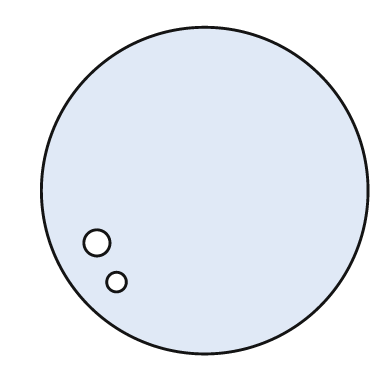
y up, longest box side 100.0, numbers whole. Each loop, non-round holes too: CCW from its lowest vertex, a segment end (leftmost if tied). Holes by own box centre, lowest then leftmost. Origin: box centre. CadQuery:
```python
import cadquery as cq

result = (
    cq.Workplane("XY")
    .moveTo(0.0, 0.0)
    .circle(50.0)
    .moveTo(-27.0, -28.0)
    .circle(3.0)
    .moveTo(-33.0, -16.0)
    .circle(4.0)
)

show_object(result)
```